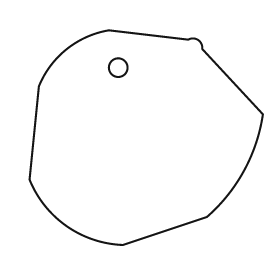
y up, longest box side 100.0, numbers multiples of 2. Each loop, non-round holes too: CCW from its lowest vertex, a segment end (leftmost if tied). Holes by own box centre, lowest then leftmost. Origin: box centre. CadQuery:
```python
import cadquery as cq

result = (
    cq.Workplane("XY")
    .moveTo(-10.0, -46.0)
    .lineTo(26.0, -34.0)
    .threePointArc((42.0, -14.0), (50.0, 10.0))
    .lineTo(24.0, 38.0)
    .threePointArc((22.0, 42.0), (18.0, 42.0))
    .lineTo(-16.0, 46.0)
    .threePointArc((-34.0, 38.0), (-46.0, 22.0))
    .lineTo(-50.0, -18.0)
    .threePointArc((-34.0, -38.0), (-10.0, -46.0))
    .close()
    .moveTo(-12.0, 30.0)
    .circle(4.0)
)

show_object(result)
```